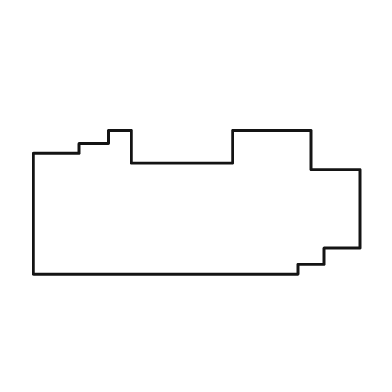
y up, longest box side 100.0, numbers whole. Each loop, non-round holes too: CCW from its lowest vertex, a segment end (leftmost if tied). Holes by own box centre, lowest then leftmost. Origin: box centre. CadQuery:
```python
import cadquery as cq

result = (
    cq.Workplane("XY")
    .moveTo(-50.0, -22.0)
    .lineTo(31.0, -22.0)
    .lineTo(31.0, -19.0)
    .lineTo(39.0, -19.0)
    .lineTo(39.0, -14.0)
    .lineTo(50.0, -14.0)
    .lineTo(50.0, 10.0)
    .lineTo(35.0, 10.0)
    .lineTo(35.0, 22.0)
    .lineTo(11.0, 22.0)
    .lineTo(11.0, 12.0)
    .lineTo(-20.0, 12.0)
    .lineTo(-20.0, 22.0)
    .lineTo(-27.0, 22.0)
    .lineTo(-27.0, 18.0)
    .lineTo(-36.0, 18.0)
    .lineTo(-36.0, 15.0)
    .lineTo(-50.0, 15.0)
    .close()
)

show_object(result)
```